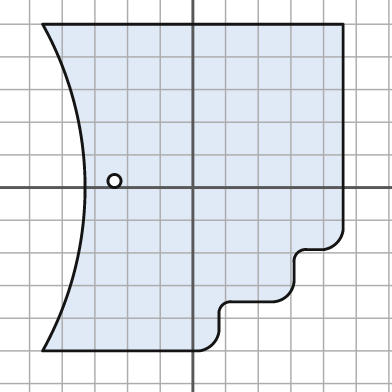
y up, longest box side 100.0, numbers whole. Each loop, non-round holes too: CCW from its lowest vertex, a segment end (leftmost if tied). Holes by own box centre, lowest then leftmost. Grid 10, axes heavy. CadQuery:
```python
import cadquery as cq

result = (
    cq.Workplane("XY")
    .moveTo(-46.0, -50.0)
    .lineTo(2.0, -50.0)
    .threePointArc((6.0, -48.0), (8.0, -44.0))
    .lineTo(8.0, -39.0)
    .threePointArc((9.0, -36.0), (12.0, -35.0))
    .lineTo(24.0, -35.0)
    .threePointArc((29.0, -33.0), (31.0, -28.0))
    .lineTo(31.0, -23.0)
    .threePointArc((32.0, -20.0), (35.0, -19.0))
    .lineTo(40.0, -19.0)
    .threePointArc((44.0, -17.0), (46.0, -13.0))
    .lineTo(46.0, 50.0)
    .lineTo(-46.0, 50.0)
    .threePointArc((-33.0, 0.0), (-46.0, -50.0))
    .close()
    .moveTo(-24.0, 2.0)
    .circle(2.0)
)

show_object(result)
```